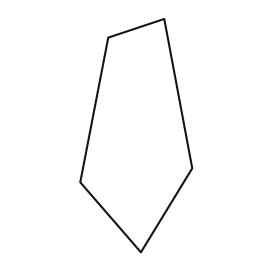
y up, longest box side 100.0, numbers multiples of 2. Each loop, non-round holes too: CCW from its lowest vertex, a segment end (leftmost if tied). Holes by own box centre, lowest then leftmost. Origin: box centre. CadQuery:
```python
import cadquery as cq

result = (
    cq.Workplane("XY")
    .moveTo(2.0, -50.0)
    .lineTo(24.0, -14.0)
    .lineTo(12.0, 50.0)
    .lineTo(-12.0, 42.0)
    .lineTo(-24.0, -20.0)
    .close()
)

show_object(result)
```